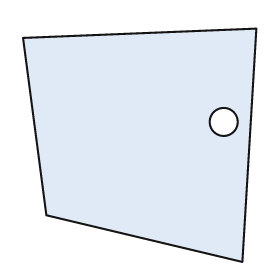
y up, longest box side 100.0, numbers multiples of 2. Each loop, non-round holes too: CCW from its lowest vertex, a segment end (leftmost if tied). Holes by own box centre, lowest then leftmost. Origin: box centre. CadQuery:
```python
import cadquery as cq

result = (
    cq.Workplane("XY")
    .moveTo(44.0, -50.0)
    .lineTo(50.0, 50.0)
    .lineTo(-50.0, 46.0)
    .lineTo(-40.0, -30.0)
    .close()
    .moveTo(36.0, 10.0)
    .circle(6.0)
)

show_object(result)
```